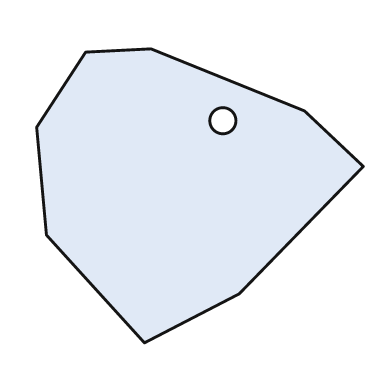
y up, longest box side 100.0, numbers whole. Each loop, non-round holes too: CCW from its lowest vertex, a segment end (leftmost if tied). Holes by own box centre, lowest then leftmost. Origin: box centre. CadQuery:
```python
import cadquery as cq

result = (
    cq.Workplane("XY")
    .moveTo(-17.0, -45.0)
    .lineTo(12.0, -30.0)
    .lineTo(50.0, 9.0)
    .lineTo(32.0, 26.0)
    .lineTo(-15.0, 45.0)
    .lineTo(-35.0, 44.0)
    .lineTo(-50.0, 21.0)
    .lineTo(-47.0, -12.0)
    .close()
    .moveTo(7.0, 23.0)
    .circle(4.0)
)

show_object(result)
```